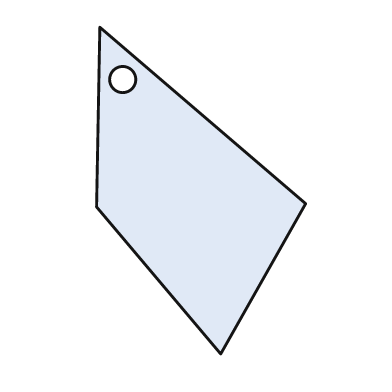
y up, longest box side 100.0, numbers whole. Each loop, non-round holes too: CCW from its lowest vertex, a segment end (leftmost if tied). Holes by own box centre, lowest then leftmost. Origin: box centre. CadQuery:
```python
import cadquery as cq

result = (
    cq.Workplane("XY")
    .moveTo(6.0, -50.0)
    .lineTo(32.0, -4.0)
    .lineTo(-31.0, 50.0)
    .lineTo(-32.0, -5.0)
    .close()
    .moveTo(-24.0, 34.0)
    .circle(4.0)
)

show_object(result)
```